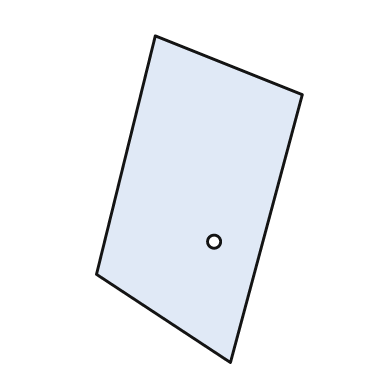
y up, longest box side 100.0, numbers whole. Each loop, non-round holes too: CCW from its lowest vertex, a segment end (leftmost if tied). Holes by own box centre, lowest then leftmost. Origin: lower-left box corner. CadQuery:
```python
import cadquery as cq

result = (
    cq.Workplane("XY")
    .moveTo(41.0, 0.0)
    .lineTo(63.0, 82.0)
    .lineTo(18.0, 100.0)
    .lineTo(0.0, 27.0)
    .close()
    .moveTo(36.0, 37.0)
    .circle(2.0)
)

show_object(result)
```